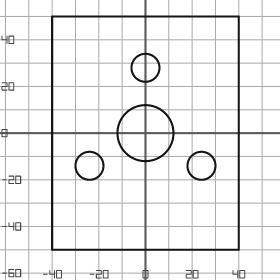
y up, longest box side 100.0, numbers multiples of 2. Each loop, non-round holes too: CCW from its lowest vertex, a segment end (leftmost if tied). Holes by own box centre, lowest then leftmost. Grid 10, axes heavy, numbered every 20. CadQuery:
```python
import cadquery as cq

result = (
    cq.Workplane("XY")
    .moveTo(-40.0, -50.0)
    .lineTo(40.0, -50.0)
    .lineTo(40.0, 50.0)
    .lineTo(-40.0, 50.0)
    .close()
    .moveTo(-24.0, -14.0)
    .circle(6.0)
    .moveTo(24.0, -14.0)
    .circle(6.0)
    .moveTo(0.0, 0.0)
    .circle(12.0)
    .moveTo(0.0, 28.0)
    .circle(6.0)
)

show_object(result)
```